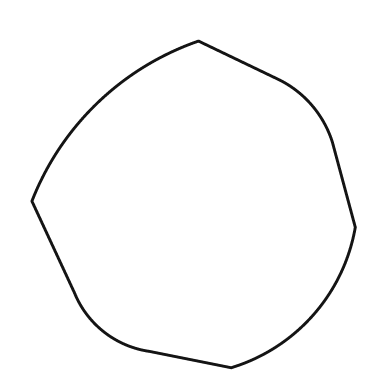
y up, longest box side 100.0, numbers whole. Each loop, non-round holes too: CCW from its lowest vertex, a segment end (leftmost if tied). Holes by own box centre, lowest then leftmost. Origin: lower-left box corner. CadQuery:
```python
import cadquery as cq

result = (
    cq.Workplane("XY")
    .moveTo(61.0, 0.0)
    .threePointArc((86.0, 16.0), (99.0, 43.0))
    .lineTo(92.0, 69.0)
    .threePointArc((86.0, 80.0), (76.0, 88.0))
    .lineTo(51.0, 100.0)
    .threePointArc((20.0, 81.0), (0.0, 51.0))
    .lineTo(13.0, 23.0)
    .threePointArc((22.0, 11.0), (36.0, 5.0))
    .close()
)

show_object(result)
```